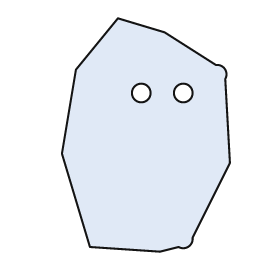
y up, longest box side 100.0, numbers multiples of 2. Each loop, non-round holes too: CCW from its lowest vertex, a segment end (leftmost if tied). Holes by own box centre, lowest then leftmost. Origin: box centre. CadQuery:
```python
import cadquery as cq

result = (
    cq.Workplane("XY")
    .moveTo(6.0, -50.0)
    .lineTo(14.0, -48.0)
    .threePointArc((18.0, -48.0), (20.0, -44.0))
    .lineTo(36.0, -12.0)
    .lineTo(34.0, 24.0)
    .threePointArc((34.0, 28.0), (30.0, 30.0))
    .lineTo(8.0, 44.0)
    .lineTo(-12.0, 50.0)
    .lineTo(-30.0, 28.0)
    .lineTo(-36.0, -8.0)
    .lineTo(-24.0, -48.0)
    .close()
    .moveTo(-2.0, 18.0)
    .circle(4.0)
    .moveTo(16.0, 18.0)
    .circle(4.0)
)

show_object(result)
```